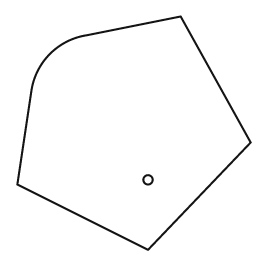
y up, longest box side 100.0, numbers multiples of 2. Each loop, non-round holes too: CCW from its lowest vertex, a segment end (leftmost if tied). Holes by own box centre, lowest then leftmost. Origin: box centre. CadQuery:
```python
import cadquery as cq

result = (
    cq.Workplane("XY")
    .moveTo(6.0, -50.0)
    .lineTo(50.0, -4.0)
    .lineTo(20.0, 50.0)
    .lineTo(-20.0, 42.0)
    .threePointArc((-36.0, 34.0), (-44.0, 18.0))
    .lineTo(-50.0, -22.0)
    .close()
    .moveTo(6.0, -20.0)
    .circle(2.0)
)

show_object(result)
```